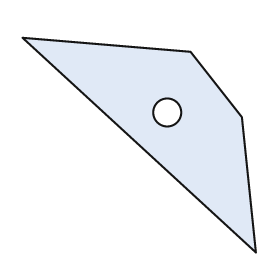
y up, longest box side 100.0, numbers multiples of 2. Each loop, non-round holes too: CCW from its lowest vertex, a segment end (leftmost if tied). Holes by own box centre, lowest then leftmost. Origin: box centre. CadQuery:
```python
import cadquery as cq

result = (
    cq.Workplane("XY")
    .moveTo(50.0, -46.0)
    .lineTo(44.0, 12.0)
    .lineTo(22.0, 40.0)
    .lineTo(-50.0, 46.0)
    .close()
    .moveTo(12.0, 14.0)
    .circle(6.0)
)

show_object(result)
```